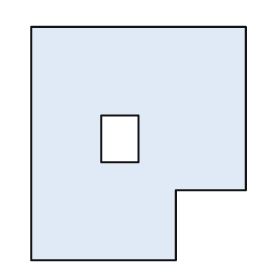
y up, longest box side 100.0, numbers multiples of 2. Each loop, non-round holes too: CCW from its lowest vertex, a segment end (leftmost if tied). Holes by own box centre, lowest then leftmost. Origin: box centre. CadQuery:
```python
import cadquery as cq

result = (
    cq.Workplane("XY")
    .moveTo(-46.0, -50.0)
    .lineTo(16.0, -50.0)
    .lineTo(16.0, -20.0)
    .lineTo(46.0, -20.0)
    .lineTo(46.0, 50.0)
    .lineTo(-46.0, 50.0)
    .close()
    .moveTo(-16.0, -8.0)
    .lineTo(0.0, -8.0)
    .lineTo(0.0, 12.0)
    .lineTo(-16.0, 12.0)
    .close()
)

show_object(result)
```